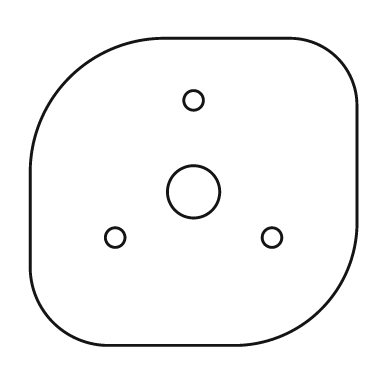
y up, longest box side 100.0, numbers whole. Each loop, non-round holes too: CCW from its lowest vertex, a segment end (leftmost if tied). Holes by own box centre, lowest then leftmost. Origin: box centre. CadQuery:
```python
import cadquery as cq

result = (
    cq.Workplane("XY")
    .moveTo(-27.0, -47.0)
    .lineTo(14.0, -47.0)
    .threePointArc((39.0, -36.0), (50.0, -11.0))
    .lineTo(50.0, 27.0)
    .threePointArc((44.0, 41.0), (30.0, 47.0))
    .lineTo(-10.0, 47.0)
    .threePointArc((-38.0, 35.0), (-50.0, 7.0))
    .lineTo(-50.0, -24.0)
    .threePointArc((-43.0, -40.0), (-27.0, -47.0))
    .close()
    .moveTo(-24.0, -14.0)
    .circle(3.0)
    .moveTo(24.0, -14.0)
    .circle(3.0)
    .moveTo(0.0, 0.0)
    .circle(8.0)
    .moveTo(0.0, 28.0)
    .circle(3.0)
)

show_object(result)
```